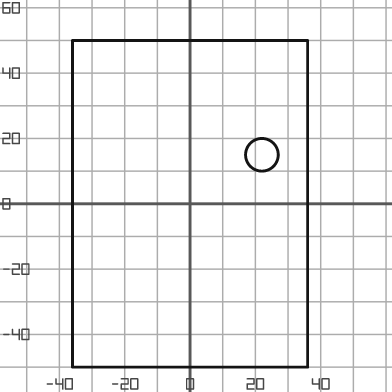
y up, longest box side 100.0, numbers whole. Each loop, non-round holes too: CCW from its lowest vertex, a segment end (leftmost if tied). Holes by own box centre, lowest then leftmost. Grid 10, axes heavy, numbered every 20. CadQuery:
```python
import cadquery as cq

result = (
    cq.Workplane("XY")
    .moveTo(-36.0, -50.0)
    .lineTo(36.0, -50.0)
    .lineTo(36.0, 50.0)
    .lineTo(-36.0, 50.0)
    .close()
    .moveTo(22.0, 15.0)
    .circle(5.0)
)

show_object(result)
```